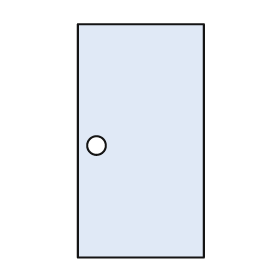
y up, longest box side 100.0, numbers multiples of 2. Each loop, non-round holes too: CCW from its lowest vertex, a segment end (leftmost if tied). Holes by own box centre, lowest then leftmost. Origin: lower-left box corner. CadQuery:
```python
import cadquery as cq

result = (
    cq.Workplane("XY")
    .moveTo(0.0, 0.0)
    .lineTo(54.0, 0.0)
    .lineTo(54.0, 100.0)
    .lineTo(0.0, 100.0)
    .close()
    .moveTo(8.0, 48.0)
    .circle(4.0)
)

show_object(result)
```